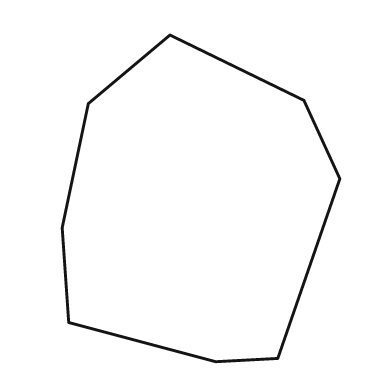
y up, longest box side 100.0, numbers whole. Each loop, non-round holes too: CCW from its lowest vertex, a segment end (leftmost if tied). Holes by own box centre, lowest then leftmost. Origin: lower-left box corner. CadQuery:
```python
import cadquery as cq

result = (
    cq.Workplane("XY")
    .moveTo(47.0, 0.0)
    .lineTo(66.0, 1.0)
    .lineTo(85.0, 56.0)
    .lineTo(74.0, 80.0)
    .lineTo(33.0, 100.0)
    .lineTo(8.0, 79.0)
    .lineTo(0.0, 41.0)
    .lineTo(2.0, 12.0)
    .close()
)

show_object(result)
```